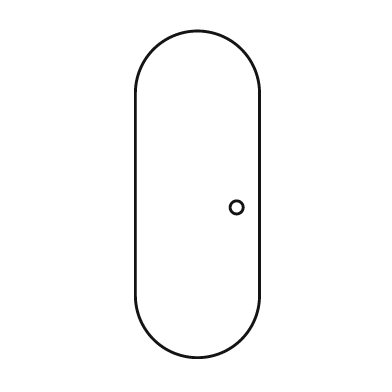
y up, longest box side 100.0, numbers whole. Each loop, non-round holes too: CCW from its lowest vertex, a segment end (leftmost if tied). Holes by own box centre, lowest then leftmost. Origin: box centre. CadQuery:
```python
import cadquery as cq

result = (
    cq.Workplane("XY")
    .moveTo(-19.0, -31.0)
    .threePointArc((0.0, -50.0), (19.0, -31.0))
    .lineTo(19.0, 31.0)
    .threePointArc((0.0, 50.0), (-19.0, 31.0))
    .close()
    .moveTo(12.0, -4.0)
    .circle(2.0)
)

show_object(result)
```